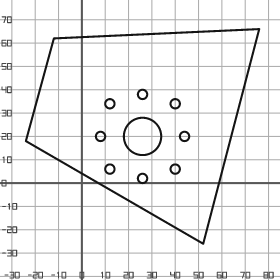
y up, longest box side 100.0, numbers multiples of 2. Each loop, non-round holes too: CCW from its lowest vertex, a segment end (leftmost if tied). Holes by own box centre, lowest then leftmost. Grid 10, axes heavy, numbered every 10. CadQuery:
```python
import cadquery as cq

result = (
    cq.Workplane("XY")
    .moveTo(52.0, -26.0)
    .lineTo(76.0, 66.0)
    .lineTo(-12.0, 62.0)
    .lineTo(-24.0, 18.0)
    .close()
    .moveTo(26.0, 2.0)
    .circle(2.0)
    .moveTo(12.0, 6.0)
    .circle(2.0)
    .moveTo(40.0, 6.0)
    .circle(2.0)
    .moveTo(8.0, 20.0)
    .circle(2.0)
    .moveTo(26.0, 20.0)
    .circle(8.0)
    .moveTo(44.0, 20.0)
    .circle(2.0)
    .moveTo(12.0, 34.0)
    .circle(2.0)
    .moveTo(40.0, 34.0)
    .circle(2.0)
    .moveTo(26.0, 38.0)
    .circle(2.0)
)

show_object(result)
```